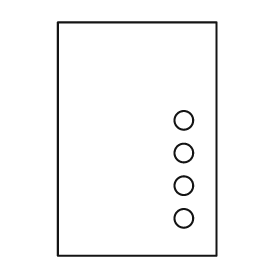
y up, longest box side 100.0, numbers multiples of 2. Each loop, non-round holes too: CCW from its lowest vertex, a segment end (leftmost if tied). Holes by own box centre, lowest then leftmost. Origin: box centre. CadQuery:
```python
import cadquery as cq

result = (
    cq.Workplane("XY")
    .moveTo(-34.0, -50.0)
    .lineTo(34.0, -50.0)
    .lineTo(34.0, 50.0)
    .lineTo(-34.0, 50.0)
    .close()
    .moveTo(20.0, -34.0)
    .circle(4.0)
    .moveTo(20.0, -20.0)
    .circle(4.0)
    .moveTo(20.0, -6.0)
    .circle(4.0)
    .moveTo(20.0, 8.0)
    .circle(4.0)
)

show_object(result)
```